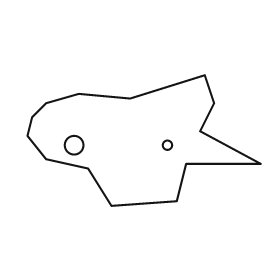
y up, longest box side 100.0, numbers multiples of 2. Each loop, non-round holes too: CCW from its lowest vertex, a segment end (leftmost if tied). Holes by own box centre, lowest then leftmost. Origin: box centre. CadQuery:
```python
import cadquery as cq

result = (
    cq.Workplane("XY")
    .moveTo(-14.0, -28.0)
    .lineTo(14.0, -26.0)
    .lineTo(18.0, -10.0)
    .lineTo(50.0, -10.0)
    .lineTo(24.0, 4.0)
    .lineTo(30.0, 16.0)
    .lineTo(26.0, 28.0)
    .lineTo(-6.0, 18.0)
    .lineTo(-28.0, 20.0)
    .lineTo(-42.0, 16.0)
    .lineTo(-48.0, 10.0)
    .lineTo(-50.0, 2.0)
    .lineTo(-42.0, -8.0)
    .lineTo(-24.0, -12.0)
    .close()
    .moveTo(-30.0, -2.0)
    .circle(4.0)
    .moveTo(10.0, -2.0)
    .circle(2.0)
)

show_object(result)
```